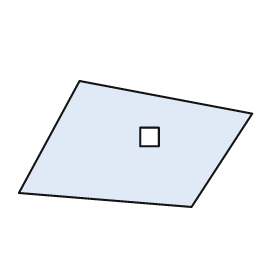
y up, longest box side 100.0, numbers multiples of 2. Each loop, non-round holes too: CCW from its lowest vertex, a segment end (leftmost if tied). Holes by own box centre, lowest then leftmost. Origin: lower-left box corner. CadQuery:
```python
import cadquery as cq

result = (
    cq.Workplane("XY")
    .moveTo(74.0, 0.0)
    .lineTo(100.0, 40.0)
    .lineTo(26.0, 54.0)
    .lineTo(0.0, 6.0)
    .close()
    .moveTo(52.0, 26.0)
    .lineTo(60.0, 26.0)
    .lineTo(60.0, 34.0)
    .lineTo(52.0, 34.0)
    .close()
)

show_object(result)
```